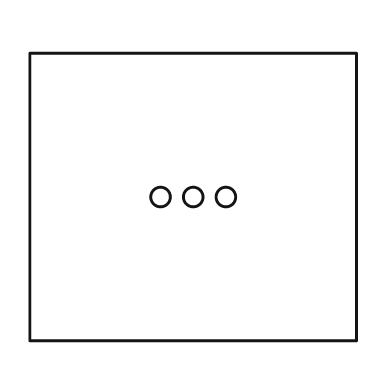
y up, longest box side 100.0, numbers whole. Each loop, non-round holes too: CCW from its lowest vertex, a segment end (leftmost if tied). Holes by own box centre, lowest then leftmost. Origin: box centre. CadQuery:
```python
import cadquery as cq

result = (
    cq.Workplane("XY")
    .moveTo(-50.0, -44.0)
    .lineTo(50.0, -44.0)
    .lineTo(50.0, 44.0)
    .lineTo(-50.0, 44.0)
    .close()
    .moveTo(-10.0, 0.0)
    .circle(3.0)
    .moveTo(0.0, 0.0)
    .circle(3.0)
    .moveTo(10.0, 0.0)
    .circle(3.0)
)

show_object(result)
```